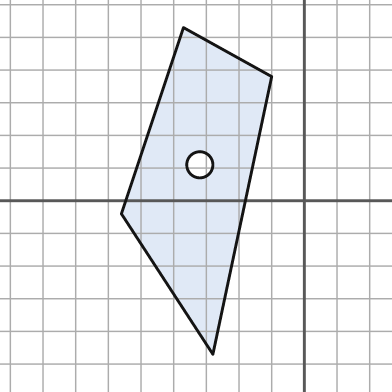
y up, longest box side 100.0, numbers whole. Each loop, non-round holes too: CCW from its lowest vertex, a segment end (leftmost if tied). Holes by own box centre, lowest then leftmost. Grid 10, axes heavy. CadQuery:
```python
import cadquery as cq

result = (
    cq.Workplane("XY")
    .moveTo(-28.0, -47.0)
    .lineTo(-10.0, 38.0)
    .lineTo(-37.0, 53.0)
    .lineTo(-56.0, -4.0)
    .close()
    .moveTo(-32.0, 11.0)
    .circle(4.0)
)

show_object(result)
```